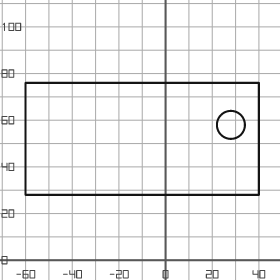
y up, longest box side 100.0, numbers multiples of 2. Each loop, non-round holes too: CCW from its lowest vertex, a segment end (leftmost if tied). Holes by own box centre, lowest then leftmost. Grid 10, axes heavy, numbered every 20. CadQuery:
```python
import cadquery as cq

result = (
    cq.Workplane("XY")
    .moveTo(-60.0, 28.0)
    .lineTo(40.0, 28.0)
    .lineTo(40.0, 76.0)
    .lineTo(-60.0, 76.0)
    .close()
    .moveTo(28.0, 58.0)
    .circle(6.0)
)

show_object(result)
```